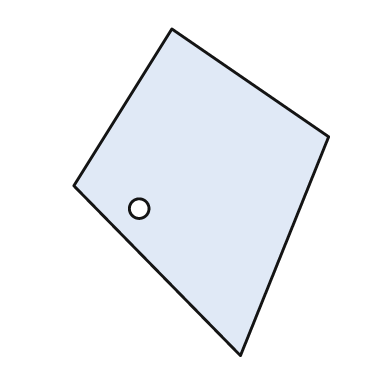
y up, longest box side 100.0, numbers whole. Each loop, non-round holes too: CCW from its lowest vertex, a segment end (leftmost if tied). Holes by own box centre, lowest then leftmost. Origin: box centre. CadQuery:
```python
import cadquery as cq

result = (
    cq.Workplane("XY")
    .moveTo(12.0, -50.0)
    .lineTo(39.0, 17.0)
    .lineTo(-9.0, 50.0)
    .lineTo(-39.0, 2.0)
    .close()
    .moveTo(-19.0, -5.0)
    .circle(3.0)
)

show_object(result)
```